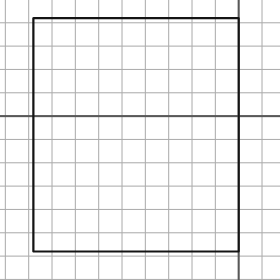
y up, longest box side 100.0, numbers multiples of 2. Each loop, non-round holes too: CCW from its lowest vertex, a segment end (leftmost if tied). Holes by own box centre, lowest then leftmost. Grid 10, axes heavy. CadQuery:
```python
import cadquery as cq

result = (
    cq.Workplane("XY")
    .moveTo(-88.0, -58.0)
    .lineTo(0.0, -58.0)
    .lineTo(0.0, 42.0)
    .lineTo(-88.0, 42.0)
    .close()
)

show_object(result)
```